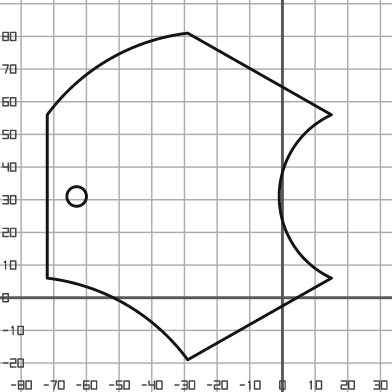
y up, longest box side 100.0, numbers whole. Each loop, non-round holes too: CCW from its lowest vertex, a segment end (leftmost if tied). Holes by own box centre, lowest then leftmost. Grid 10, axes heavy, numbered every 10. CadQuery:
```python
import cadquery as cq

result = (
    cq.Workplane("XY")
    .moveTo(-29.0, -19.0)
    .lineTo(15.0, 6.0)
    .threePointArc((-1.0, 31.0), (15.0, 56.0))
    .lineTo(-29.0, 81.0)
    .threePointArc((-53.0, 73.0), (-72.0, 56.0))
    .lineTo(-72.0, 6.0)
    .threePointArc((-48.0, -2.0), (-29.0, -19.0))
    .close()
    .moveTo(-63.0, 31.0)
    .circle(3.0)
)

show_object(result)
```